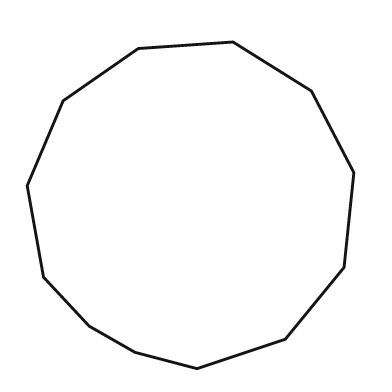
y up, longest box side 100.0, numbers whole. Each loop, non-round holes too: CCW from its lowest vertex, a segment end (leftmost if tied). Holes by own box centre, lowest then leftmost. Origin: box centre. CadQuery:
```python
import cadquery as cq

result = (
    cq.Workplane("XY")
    .moveTo(2.0, -50.0)
    .lineTo(29.0, -41.0)
    .lineTo(47.0, -19.0)
    .lineTo(50.0, 10.0)
    .lineTo(37.0, 35.0)
    .lineTo(13.0, 50.0)
    .lineTo(-16.0, 48.0)
    .lineTo(-39.0, 32.0)
    .lineTo(-50.0, 6.0)
    .lineTo(-45.0, -22.0)
    .lineTo(-31.0, -37.0)
    .lineTo(-17.0, -45.0)
    .close()
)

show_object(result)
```